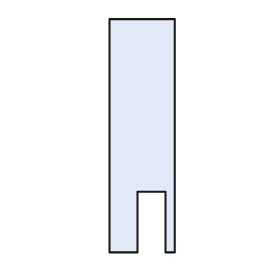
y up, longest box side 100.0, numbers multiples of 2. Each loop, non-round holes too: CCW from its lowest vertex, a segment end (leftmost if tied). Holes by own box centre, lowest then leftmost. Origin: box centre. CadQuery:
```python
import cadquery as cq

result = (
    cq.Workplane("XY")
    .moveTo(-14.0, -50.0)
    .lineTo(-2.0, -50.0)
    .lineTo(-2.0, -24.0)
    .lineTo(10.0, -24.0)
    .lineTo(10.0, -50.0)
    .lineTo(14.0, -50.0)
    .lineTo(14.0, 50.0)
    .lineTo(-14.0, 50.0)
    .close()
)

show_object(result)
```